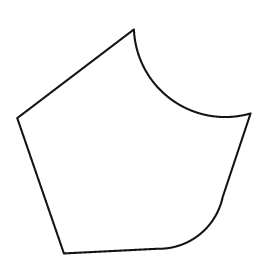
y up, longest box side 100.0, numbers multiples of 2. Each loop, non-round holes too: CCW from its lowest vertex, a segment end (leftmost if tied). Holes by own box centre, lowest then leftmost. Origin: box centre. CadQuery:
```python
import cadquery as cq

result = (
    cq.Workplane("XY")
    .moveTo(-30.0, -48.0)
    .lineTo(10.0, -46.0)
    .threePointArc((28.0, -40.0), (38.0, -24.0))
    .lineTo(50.0, 12.0)
    .threePointArc((16.0, 18.0), (0.0, 48.0))
    .lineTo(-50.0, 10.0)
    .close()
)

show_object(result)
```